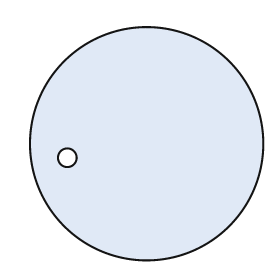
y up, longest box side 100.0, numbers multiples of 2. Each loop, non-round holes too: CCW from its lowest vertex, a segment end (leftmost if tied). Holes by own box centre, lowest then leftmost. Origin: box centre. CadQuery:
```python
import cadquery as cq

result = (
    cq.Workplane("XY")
    .moveTo(0.0, 0.0)
    .circle(50.0)
    .moveTo(-34.0, -6.0)
    .circle(4.0)
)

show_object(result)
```